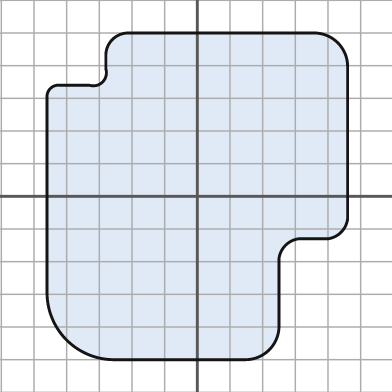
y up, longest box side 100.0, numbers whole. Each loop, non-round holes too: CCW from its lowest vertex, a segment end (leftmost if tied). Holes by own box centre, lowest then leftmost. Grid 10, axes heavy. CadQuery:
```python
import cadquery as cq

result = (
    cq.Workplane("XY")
    .moveTo(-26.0, -50.0)
    .lineTo(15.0, -50.0)
    .threePointArc((22.0, -47.0), (25.0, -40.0))
    .lineTo(25.0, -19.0)
    .threePointArc((27.0, -15.0), (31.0, -13.0))
    .lineTo(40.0, -13.0)
    .threePointArc((44.0, -11.0), (46.0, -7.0))
    .lineTo(46.0, 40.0)
    .threePointArc((43.0, 47.0), (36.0, 50.0))
    .lineTo(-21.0, 50.0)
    .threePointArc((-26.0, 48.0), (-28.0, 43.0))
    .lineTo(-28.0, 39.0)
    .threePointArc((-29.0, 35.0), (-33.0, 34.0))
    .lineTo(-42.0, 34.0)
    .threePointArc((-45.0, 33.0), (-46.0, 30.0))
    .lineTo(-46.0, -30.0)
    .threePointArc((-40.0, -44.0), (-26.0, -50.0))
    .close()
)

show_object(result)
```